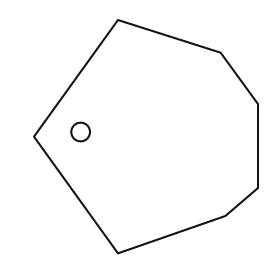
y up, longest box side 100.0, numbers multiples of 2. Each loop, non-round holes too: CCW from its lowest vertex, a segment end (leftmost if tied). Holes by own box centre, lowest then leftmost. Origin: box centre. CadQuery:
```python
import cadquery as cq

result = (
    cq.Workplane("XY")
    .moveTo(-12.0, -50.0)
    .lineTo(34.0, -34.0)
    .lineTo(48.0, -22.0)
    .lineTo(48.0, 14.0)
    .lineTo(32.0, 36.0)
    .lineTo(-12.0, 50.0)
    .lineTo(-48.0, 0.0)
    .close()
    .moveTo(-28.0, 2.0)
    .circle(4.0)
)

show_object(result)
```